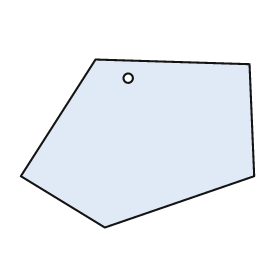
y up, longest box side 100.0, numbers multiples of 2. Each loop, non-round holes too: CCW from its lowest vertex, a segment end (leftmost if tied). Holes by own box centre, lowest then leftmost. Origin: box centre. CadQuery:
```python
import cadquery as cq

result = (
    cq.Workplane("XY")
    .moveTo(-14.0, -36.0)
    .lineTo(50.0, -14.0)
    .lineTo(48.0, 34.0)
    .lineTo(-18.0, 36.0)
    .lineTo(-50.0, -14.0)
    .close()
    .moveTo(-4.0, 28.0)
    .circle(2.0)
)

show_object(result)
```